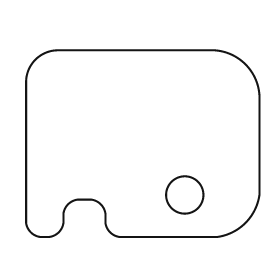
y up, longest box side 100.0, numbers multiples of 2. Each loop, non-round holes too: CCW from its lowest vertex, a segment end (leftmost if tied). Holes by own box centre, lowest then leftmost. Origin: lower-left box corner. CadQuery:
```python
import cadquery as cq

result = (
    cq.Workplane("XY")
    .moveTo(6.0, 0.0)
    .lineTo(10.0, 0.0)
    .threePointArc((14.0, 2.0), (16.0, 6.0))
    .lineTo(16.0, 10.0)
    .threePointArc((18.0, 14.0), (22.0, 16.0))
    .lineTo(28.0, 16.0)
    .threePointArc((32.0, 14.0), (34.0, 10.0))
    .lineTo(34.0, 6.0)
    .threePointArc((36.0, 2.0), (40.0, 0.0))
    .lineTo(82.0, 0.0)
    .threePointArc((94.0, 6.0), (100.0, 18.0))
    .lineTo(100.0, 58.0)
    .threePointArc((94.0, 74.0), (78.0, 80.0))
    .lineTo(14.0, 80.0)
    .threePointArc((4.0, 76.0), (0.0, 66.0))
    .lineTo(0.0, 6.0)
    .threePointArc((2.0, 2.0), (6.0, 0.0))
    .close()
    .moveTo(68.0, 18.0)
    .circle(8.0)
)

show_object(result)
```